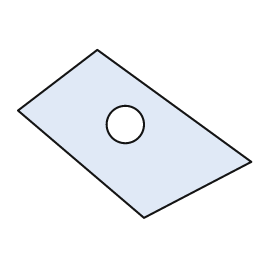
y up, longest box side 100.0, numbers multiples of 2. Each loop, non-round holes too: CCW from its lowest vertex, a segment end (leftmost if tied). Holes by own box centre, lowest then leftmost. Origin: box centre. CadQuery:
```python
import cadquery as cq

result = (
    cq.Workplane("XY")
    .moveTo(4.0, -36.0)
    .lineTo(50.0, -12.0)
    .lineTo(-16.0, 36.0)
    .lineTo(-50.0, 10.0)
    .close()
    .moveTo(-4.0, 4.0)
    .circle(8.0)
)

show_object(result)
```